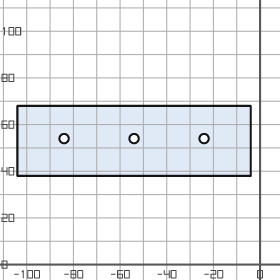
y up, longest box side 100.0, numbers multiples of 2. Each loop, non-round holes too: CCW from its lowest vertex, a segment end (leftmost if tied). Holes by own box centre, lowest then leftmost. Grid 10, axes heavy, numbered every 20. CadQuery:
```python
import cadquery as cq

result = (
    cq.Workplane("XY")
    .moveTo(-104.0, 38.0)
    .lineTo(-4.0, 38.0)
    .lineTo(-4.0, 68.0)
    .lineTo(-104.0, 68.0)
    .close()
    .moveTo(-84.0, 54.0)
    .circle(2.0)
    .moveTo(-54.0, 54.0)
    .circle(2.0)
    .moveTo(-24.0, 54.0)
    .circle(2.0)
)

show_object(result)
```